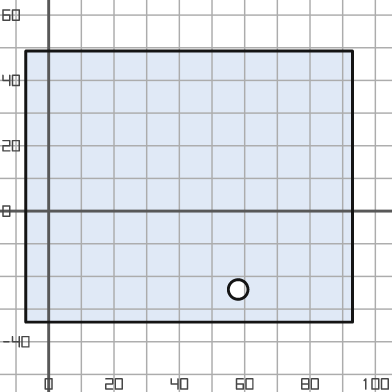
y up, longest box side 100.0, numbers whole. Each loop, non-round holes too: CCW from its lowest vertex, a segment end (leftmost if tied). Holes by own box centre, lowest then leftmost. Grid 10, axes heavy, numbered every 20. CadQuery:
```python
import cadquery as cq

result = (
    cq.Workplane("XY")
    .moveTo(-7.0, -34.0)
    .lineTo(93.0, -34.0)
    .lineTo(93.0, 49.0)
    .lineTo(-7.0, 49.0)
    .close()
    .moveTo(58.0, -24.0)
    .circle(3.0)
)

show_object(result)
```